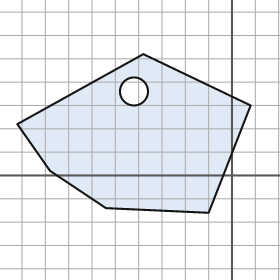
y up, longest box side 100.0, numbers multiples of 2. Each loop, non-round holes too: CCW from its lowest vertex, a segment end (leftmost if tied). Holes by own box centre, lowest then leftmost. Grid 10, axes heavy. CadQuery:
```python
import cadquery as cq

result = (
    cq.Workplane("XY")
    .moveTo(-10.0, -16.0)
    .lineTo(8.0, 30.0)
    .lineTo(-38.0, 52.0)
    .lineTo(-92.0, 22.0)
    .lineTo(-78.0, 2.0)
    .lineTo(-54.0, -14.0)
    .close()
    .moveTo(-42.0, 36.0)
    .circle(6.0)
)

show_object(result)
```